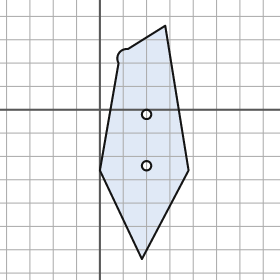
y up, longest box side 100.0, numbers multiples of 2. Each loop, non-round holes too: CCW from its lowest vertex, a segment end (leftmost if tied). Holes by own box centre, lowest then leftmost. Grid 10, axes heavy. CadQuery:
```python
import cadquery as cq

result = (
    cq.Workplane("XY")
    .moveTo(18.0, -64.0)
    .lineTo(38.0, -26.0)
    .lineTo(28.0, 36.0)
    .lineTo(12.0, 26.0)
    .threePointArc((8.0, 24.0), (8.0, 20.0))
    .lineTo(0.0, -26.0)
    .close()
    .moveTo(20.0, -24.0)
    .circle(2.0)
    .moveTo(20.0, -2.0)
    .circle(2.0)
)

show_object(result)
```